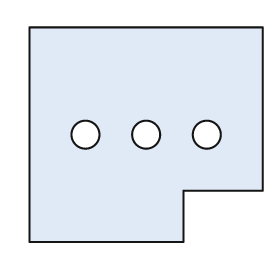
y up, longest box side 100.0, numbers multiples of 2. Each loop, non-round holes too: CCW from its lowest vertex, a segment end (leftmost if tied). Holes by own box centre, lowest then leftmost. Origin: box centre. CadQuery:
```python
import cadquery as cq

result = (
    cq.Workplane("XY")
    .moveTo(-50.0, -46.0)
    .lineTo(16.0, -46.0)
    .lineTo(16.0, -24.0)
    .lineTo(50.0, -24.0)
    .lineTo(50.0, 46.0)
    .lineTo(-50.0, 46.0)
    .close()
    .moveTo(-26.0, 0.0)
    .circle(6.0)
    .moveTo(0.0, 0.0)
    .circle(6.0)
    .moveTo(26.0, 0.0)
    .circle(6.0)
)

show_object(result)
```